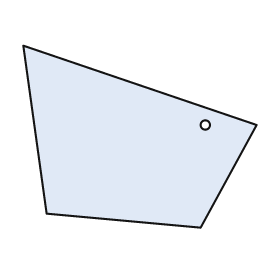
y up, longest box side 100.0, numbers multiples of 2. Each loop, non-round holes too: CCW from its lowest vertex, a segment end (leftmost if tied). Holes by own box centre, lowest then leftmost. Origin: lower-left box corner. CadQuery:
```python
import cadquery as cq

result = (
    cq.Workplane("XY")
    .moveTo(76.0, 0.0)
    .lineTo(100.0, 44.0)
    .lineTo(0.0, 78.0)
    .lineTo(10.0, 6.0)
    .close()
    .moveTo(78.0, 44.0)
    .circle(2.0)
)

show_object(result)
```